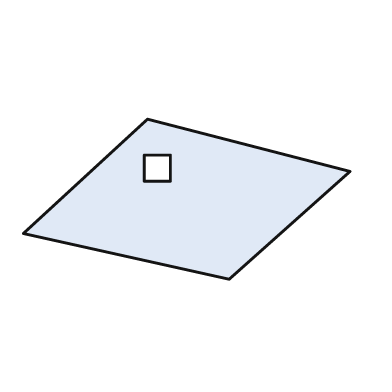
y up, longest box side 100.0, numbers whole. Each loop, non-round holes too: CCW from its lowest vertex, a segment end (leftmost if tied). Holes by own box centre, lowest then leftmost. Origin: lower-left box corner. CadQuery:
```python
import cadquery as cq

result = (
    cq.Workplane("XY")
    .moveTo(63.0, 0.0)
    .lineTo(100.0, 33.0)
    .lineTo(38.0, 49.0)
    .lineTo(0.0, 14.0)
    .close()
    .moveTo(37.0, 30.0)
    .lineTo(45.0, 30.0)
    .lineTo(45.0, 38.0)
    .lineTo(37.0, 38.0)
    .close()
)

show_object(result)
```